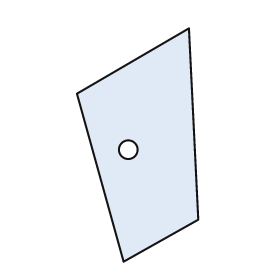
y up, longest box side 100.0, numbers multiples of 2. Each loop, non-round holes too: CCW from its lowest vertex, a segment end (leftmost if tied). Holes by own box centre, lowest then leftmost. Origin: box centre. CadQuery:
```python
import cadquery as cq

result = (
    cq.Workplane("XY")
    .moveTo(-6.0, -50.0)
    .lineTo(26.0, -32.0)
    .lineTo(22.0, 50.0)
    .lineTo(-26.0, 22.0)
    .close()
    .moveTo(-4.0, -2.0)
    .circle(4.0)
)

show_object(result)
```